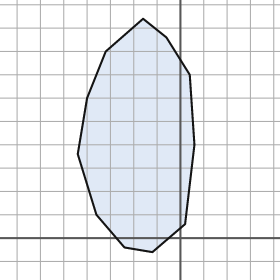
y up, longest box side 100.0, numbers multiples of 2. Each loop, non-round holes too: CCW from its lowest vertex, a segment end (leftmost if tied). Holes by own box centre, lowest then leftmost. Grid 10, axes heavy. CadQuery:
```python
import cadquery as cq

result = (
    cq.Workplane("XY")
    .moveTo(-12.0, -6.0)
    .lineTo(2.0, 6.0)
    .lineTo(6.0, 40.0)
    .lineTo(4.0, 70.0)
    .lineTo(-6.0, 86.0)
    .lineTo(-16.0, 94.0)
    .lineTo(-32.0, 80.0)
    .lineTo(-40.0, 60.0)
    .lineTo(-44.0, 36.0)
    .lineTo(-36.0, 10.0)
    .lineTo(-24.0, -4.0)
    .close()
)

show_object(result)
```